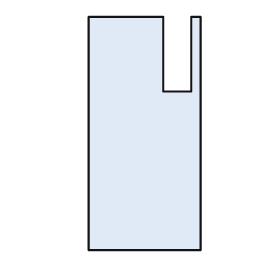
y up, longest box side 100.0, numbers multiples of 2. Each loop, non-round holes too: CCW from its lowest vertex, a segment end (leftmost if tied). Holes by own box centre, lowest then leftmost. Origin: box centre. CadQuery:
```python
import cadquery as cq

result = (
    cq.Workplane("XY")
    .moveTo(-24.0, -50.0)
    .lineTo(24.0, -50.0)
    .lineTo(24.0, 50.0)
    .lineTo(20.0, 50.0)
    .lineTo(20.0, 18.0)
    .lineTo(8.0, 18.0)
    .lineTo(8.0, 50.0)
    .lineTo(-24.0, 50.0)
    .close()
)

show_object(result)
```